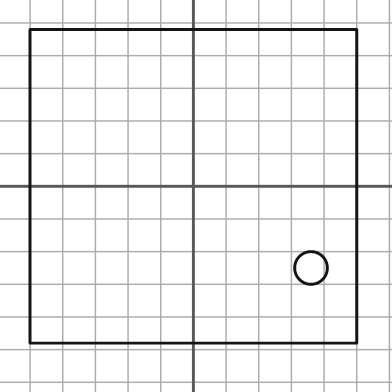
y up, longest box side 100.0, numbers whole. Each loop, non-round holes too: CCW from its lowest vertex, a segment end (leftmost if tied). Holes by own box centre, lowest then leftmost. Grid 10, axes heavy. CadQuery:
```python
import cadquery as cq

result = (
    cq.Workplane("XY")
    .moveTo(-50.0, -48.0)
    .lineTo(50.0, -48.0)
    .lineTo(50.0, 48.0)
    .lineTo(-50.0, 48.0)
    .close()
    .moveTo(36.0, -25.0)
    .circle(5.0)
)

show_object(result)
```